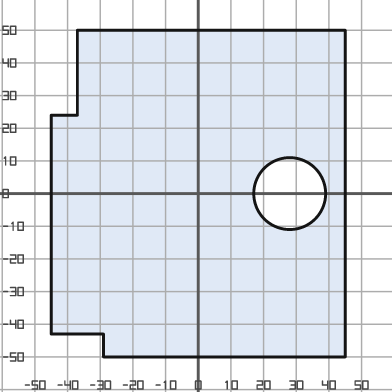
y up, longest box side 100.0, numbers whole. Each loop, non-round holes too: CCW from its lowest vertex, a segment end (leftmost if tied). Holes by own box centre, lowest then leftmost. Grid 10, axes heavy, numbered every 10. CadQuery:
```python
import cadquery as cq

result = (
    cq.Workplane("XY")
    .moveTo(-29.0, -50.0)
    .lineTo(45.0, -50.0)
    .lineTo(45.0, 50.0)
    .lineTo(-37.0, 50.0)
    .lineTo(-37.0, 24.0)
    .lineTo(-45.0, 24.0)
    .lineTo(-45.0, -43.0)
    .lineTo(-29.0, -43.0)
    .close()
    .moveTo(28.0, 0.0)
    .circle(11.0)
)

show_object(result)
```